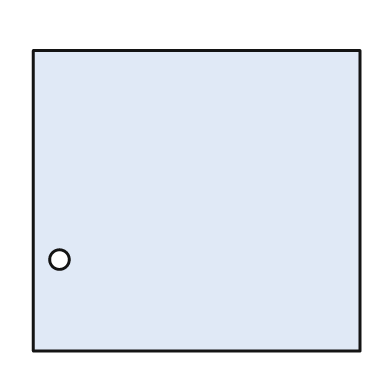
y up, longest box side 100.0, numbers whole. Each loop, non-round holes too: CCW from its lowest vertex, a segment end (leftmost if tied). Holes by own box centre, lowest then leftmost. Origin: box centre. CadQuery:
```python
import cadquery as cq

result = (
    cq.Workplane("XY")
    .moveTo(-50.0, -46.0)
    .lineTo(50.0, -46.0)
    .lineTo(50.0, 46.0)
    .lineTo(-50.0, 46.0)
    .close()
    .moveTo(-42.0, -18.0)
    .circle(3.0)
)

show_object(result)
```